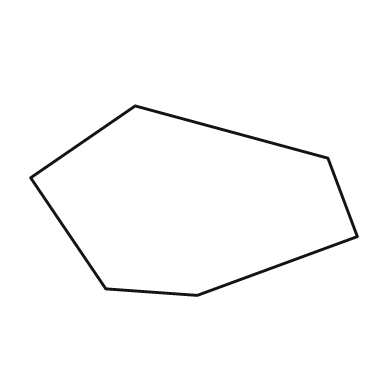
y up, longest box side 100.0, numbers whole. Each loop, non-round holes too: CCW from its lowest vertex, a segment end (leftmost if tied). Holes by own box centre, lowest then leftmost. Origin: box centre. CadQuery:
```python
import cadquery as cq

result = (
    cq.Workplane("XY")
    .moveTo(1.0, -29.0)
    .lineTo(50.0, -11.0)
    .lineTo(41.0, 13.0)
    .lineTo(-18.0, 29.0)
    .lineTo(-50.0, 7.0)
    .lineTo(-27.0, -27.0)
    .close()
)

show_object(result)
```